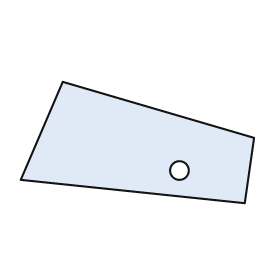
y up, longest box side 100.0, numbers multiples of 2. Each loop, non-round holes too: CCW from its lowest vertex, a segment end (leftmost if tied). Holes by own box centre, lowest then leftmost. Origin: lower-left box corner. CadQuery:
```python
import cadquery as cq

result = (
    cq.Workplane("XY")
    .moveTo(96.0, 0.0)
    .lineTo(100.0, 28.0)
    .lineTo(18.0, 52.0)
    .lineTo(0.0, 10.0)
    .close()
    .moveTo(68.0, 14.0)
    .circle(4.0)
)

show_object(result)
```